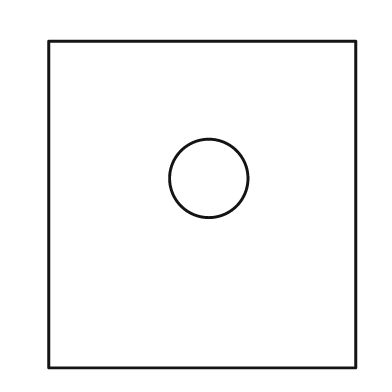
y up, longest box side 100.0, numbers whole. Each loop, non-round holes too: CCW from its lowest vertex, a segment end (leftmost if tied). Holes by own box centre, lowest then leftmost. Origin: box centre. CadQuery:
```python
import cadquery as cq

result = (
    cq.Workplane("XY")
    .moveTo(-47.0, -50.0)
    .lineTo(47.0, -50.0)
    .lineTo(47.0, 50.0)
    .lineTo(-47.0, 50.0)
    .close()
    .moveTo(2.0, 8.0)
    .circle(12.0)
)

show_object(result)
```